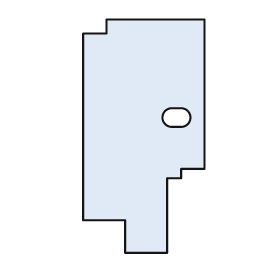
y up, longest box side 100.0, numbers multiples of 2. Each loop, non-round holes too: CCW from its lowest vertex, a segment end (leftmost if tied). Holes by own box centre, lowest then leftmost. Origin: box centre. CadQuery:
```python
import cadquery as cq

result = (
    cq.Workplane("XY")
    .moveTo(-8.0, -50.0)
    .lineTo(10.0, -50.0)
    .lineTo(10.0, -18.0)
    .lineTo(16.0, -18.0)
    .lineTo(16.0, -14.0)
    .lineTo(26.0, -14.0)
    .lineTo(26.0, 50.0)
    .lineTo(-16.0, 50.0)
    .lineTo(-16.0, 44.0)
    .lineTo(-26.0, 44.0)
    .lineTo(-26.0, -36.0)
    .lineTo(-8.0, -36.0)
    .close()
    .moveTo(12.0, 4.0)
    .lineTo(16.0, 4.0)
    .threePointArc((20.0, 8.0), (16.0, 12.0))
    .lineTo(12.0, 12.0)
    .threePointArc((8.0, 8.0), (12.0, 4.0))
    .close()
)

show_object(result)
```